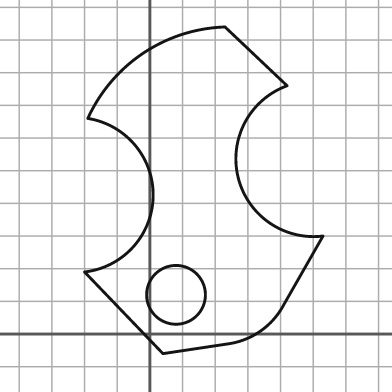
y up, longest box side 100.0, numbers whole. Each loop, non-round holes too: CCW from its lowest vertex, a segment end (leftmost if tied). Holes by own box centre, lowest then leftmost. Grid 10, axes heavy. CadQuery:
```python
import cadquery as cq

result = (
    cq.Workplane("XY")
    .moveTo(4.0, -6.0)
    .lineTo(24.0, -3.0)
    .threePointArc((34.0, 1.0), (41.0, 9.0))
    .lineTo(53.0, 30.0)
    .threePointArc((27.0, 48.0), (42.0, 76.0))
    .lineTo(23.0, 94.0)
    .threePointArc((-2.0, 86.0), (-19.0, 66.0))
    .threePointArc((1.0, 42.0), (-20.0, 19.0))
    .close()
    .moveTo(8.0, 12.0)
    .circle(9.0)
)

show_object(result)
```